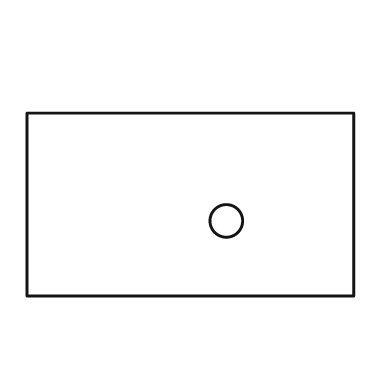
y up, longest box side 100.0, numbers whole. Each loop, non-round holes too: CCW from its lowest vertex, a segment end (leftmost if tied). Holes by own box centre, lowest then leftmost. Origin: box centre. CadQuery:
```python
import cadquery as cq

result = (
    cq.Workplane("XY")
    .moveTo(-50.0, -28.0)
    .lineTo(50.0, -28.0)
    .lineTo(50.0, 28.0)
    .lineTo(-50.0, 28.0)
    .close()
    .moveTo(11.0, -5.0)
    .circle(5.0)
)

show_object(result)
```